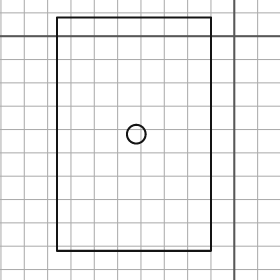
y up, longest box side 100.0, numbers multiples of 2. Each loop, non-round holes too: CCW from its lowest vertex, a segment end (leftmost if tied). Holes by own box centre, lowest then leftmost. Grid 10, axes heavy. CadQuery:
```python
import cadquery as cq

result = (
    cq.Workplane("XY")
    .moveTo(-76.0, -92.0)
    .lineTo(-10.0, -92.0)
    .lineTo(-10.0, 8.0)
    .lineTo(-76.0, 8.0)
    .close()
    .moveTo(-42.0, -42.0)
    .circle(4.0)
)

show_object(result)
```